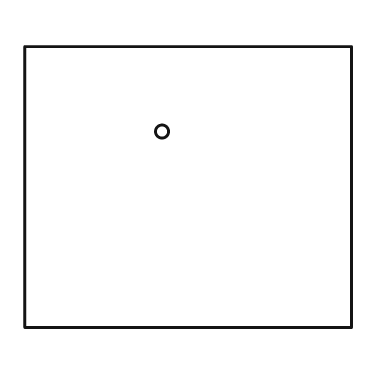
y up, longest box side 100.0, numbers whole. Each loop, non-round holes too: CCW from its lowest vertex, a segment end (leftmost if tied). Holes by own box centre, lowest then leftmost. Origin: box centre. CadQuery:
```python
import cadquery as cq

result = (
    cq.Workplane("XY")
    .moveTo(-50.0, -43.0)
    .lineTo(50.0, -43.0)
    .lineTo(50.0, 43.0)
    .lineTo(-50.0, 43.0)
    .close()
    .moveTo(-8.0, 17.0)
    .circle(2.0)
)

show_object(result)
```